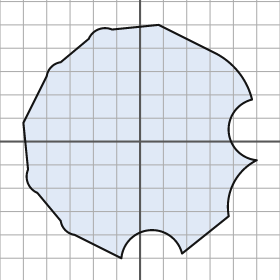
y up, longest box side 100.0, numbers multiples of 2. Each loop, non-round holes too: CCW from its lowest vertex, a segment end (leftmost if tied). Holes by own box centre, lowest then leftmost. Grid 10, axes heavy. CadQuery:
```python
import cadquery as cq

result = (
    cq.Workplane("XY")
    .moveTo(-8.0, -50.0)
    .threePointArc((4.0, -38.0), (18.0, -48.0))
    .lineTo(38.0, -32.0)
    .threePointArc((40.0, -18.0), (50.0, -8.0))
    .threePointArc((38.0, 4.0), (48.0, 18.0))
    .threePointArc((42.0, 30.0), (32.0, 38.0))
    .lineTo(8.0, 50.0)
    .lineTo(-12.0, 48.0)
    .threePointArc((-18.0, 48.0), (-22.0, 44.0))
    .lineTo(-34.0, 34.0)
    .threePointArc((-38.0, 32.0), (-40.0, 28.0))
    .lineTo(-50.0, 8.0)
    .lineTo(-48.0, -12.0)
    .threePointArc((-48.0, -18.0), (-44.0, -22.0))
    .lineTo(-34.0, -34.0)
    .threePointArc((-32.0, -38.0), (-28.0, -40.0))
    .close()
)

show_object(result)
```